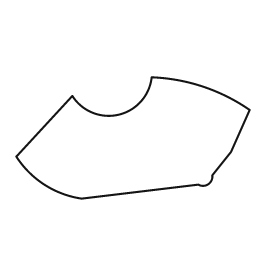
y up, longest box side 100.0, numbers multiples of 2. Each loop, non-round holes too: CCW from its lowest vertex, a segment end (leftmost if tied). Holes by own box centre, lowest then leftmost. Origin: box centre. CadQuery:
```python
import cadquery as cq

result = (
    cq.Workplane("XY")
    .moveTo(-22.0, -26.0)
    .lineTo(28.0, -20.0)
    .threePointArc((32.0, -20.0), (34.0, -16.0))
    .lineTo(42.0, -6.0)
    .lineTo(50.0, 12.0)
    .threePointArc((30.0, 22.0), (8.0, 26.0))
    .threePointArc((-6.0, 10.0), (-26.0, 18.0))
    .lineTo(-50.0, -8.0)
    .threePointArc((-38.0, -20.0), (-22.0, -26.0))
    .close()
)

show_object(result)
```